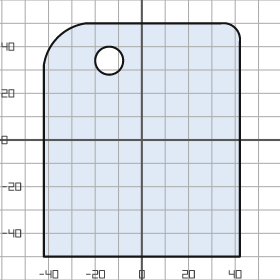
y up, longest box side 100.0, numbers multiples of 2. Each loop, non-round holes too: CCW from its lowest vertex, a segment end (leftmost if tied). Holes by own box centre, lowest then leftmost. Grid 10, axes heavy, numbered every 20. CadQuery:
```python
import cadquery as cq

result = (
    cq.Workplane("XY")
    .moveTo(-42.0, -50.0)
    .lineTo(42.0, -50.0)
    .lineTo(42.0, 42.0)
    .threePointArc((40.0, 48.0), (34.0, 50.0))
    .lineTo(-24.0, 50.0)
    .threePointArc((-36.0, 44.0), (-42.0, 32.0))
    .close()
    .moveTo(-14.0, 34.0)
    .circle(6.0)
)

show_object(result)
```